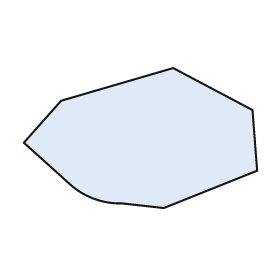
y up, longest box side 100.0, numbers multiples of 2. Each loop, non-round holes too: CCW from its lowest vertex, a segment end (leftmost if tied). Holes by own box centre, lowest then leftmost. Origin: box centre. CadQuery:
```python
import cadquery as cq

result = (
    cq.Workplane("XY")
    .moveTo(10.0, -30.0)
    .lineTo(50.0, -14.0)
    .lineTo(48.0, 12.0)
    .lineTo(14.0, 30.0)
    .lineTo(-34.0, 16.0)
    .lineTo(-50.0, -2.0)
    .lineTo(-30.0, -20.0)
    .threePointArc((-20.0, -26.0), (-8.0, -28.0))
    .close()
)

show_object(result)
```